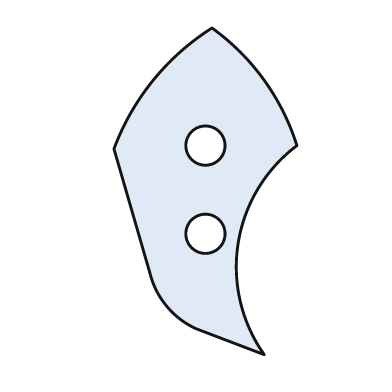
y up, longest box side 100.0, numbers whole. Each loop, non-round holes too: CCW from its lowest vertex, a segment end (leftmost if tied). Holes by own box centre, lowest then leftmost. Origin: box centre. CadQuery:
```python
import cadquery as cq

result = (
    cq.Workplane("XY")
    .moveTo(18.0, -50.0)
    .threePointArc((10.0, -16.0), (28.0, 14.0))
    .threePointArc((18.0, 34.0), (2.0, 50.0))
    .threePointArc((-16.0, 34.0), (-28.0, 13.0))
    .lineTo(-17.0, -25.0)
    .threePointArc((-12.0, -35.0), (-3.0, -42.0))
    .close()
    .moveTo(0.0, -13.0)
    .circle(6.0)
    .moveTo(0.0, 14.0)
    .circle(6.0)
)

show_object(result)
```